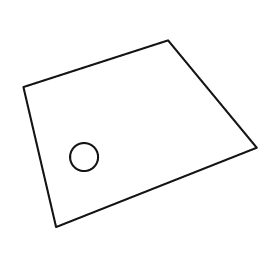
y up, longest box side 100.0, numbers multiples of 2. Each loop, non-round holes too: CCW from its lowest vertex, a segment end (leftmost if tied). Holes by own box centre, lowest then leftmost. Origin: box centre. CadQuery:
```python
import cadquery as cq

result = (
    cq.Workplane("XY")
    .moveTo(-36.0, -40.0)
    .lineTo(50.0, -6.0)
    .lineTo(12.0, 40.0)
    .lineTo(-50.0, 20.0)
    .close()
    .moveTo(-24.0, -10.0)
    .circle(6.0)
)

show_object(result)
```